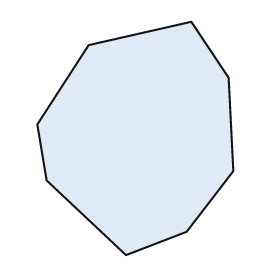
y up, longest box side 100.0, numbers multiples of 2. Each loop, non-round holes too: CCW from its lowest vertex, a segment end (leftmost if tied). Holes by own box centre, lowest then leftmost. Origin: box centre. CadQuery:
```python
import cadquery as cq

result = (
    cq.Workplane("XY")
    .moveTo(-4.0, -50.0)
    .lineTo(22.0, -40.0)
    .lineTo(42.0, -14.0)
    .lineTo(40.0, 26.0)
    .lineTo(24.0, 50.0)
    .lineTo(-20.0, 40.0)
    .lineTo(-42.0, 6.0)
    .lineTo(-38.0, -18.0)
    .close()
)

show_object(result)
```